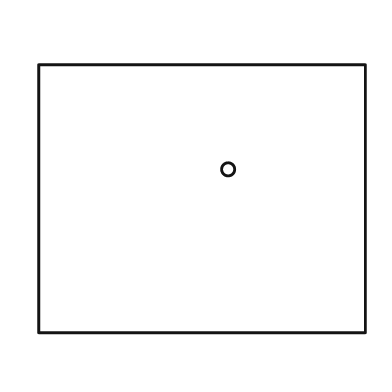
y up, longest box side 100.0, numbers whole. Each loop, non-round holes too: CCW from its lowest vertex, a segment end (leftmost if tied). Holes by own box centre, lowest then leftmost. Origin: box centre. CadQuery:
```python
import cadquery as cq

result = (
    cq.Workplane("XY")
    .moveTo(-50.0, -41.0)
    .lineTo(50.0, -41.0)
    .lineTo(50.0, 41.0)
    .lineTo(-50.0, 41.0)
    .close()
    .moveTo(8.0, 9.0)
    .circle(2.0)
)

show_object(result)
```